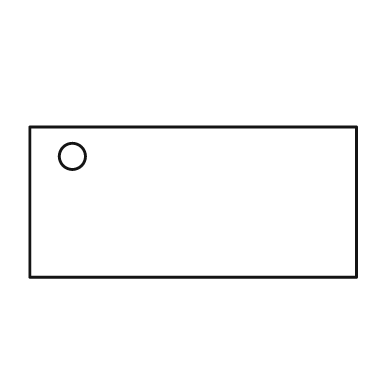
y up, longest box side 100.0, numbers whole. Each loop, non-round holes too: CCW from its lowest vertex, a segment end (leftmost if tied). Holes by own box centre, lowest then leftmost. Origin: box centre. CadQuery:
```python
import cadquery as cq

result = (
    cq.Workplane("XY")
    .moveTo(-50.0, -23.0)
    .lineTo(50.0, -23.0)
    .lineTo(50.0, 23.0)
    .lineTo(-50.0, 23.0)
    .close()
    .moveTo(-37.0, 14.0)
    .circle(4.0)
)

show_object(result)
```